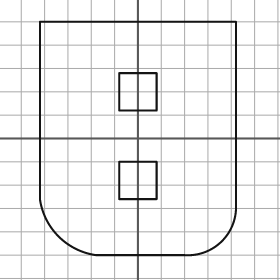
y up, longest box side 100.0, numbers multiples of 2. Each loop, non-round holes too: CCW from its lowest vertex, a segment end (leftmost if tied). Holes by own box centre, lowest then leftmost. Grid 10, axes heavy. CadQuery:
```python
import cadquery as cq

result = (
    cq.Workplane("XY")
    .moveTo(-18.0, -50.0)
    .lineTo(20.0, -50.0)
    .threePointArc((36.0, -44.0), (42.0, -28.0))
    .lineTo(42.0, 50.0)
    .lineTo(-42.0, 50.0)
    .lineTo(-42.0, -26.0)
    .threePointArc((-34.0, -42.0), (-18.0, -50.0))
    .close()
    .moveTo(-8.0, -26.0)
    .lineTo(8.0, -26.0)
    .lineTo(8.0, -10.0)
    .lineTo(-8.0, -10.0)
    .close()
    .moveTo(-8.0, 12.0)
    .lineTo(8.0, 12.0)
    .lineTo(8.0, 28.0)
    .lineTo(-8.0, 28.0)
    .close()
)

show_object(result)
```